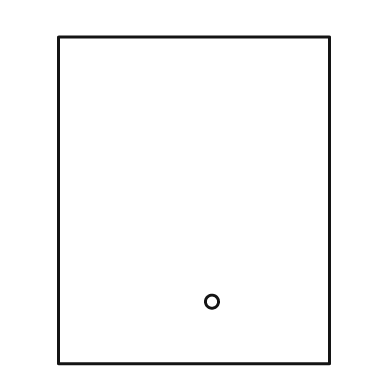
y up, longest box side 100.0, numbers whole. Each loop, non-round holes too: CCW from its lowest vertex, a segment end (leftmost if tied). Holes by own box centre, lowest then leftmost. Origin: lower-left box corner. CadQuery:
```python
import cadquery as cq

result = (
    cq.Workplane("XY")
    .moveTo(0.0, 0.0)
    .lineTo(83.0, 0.0)
    .lineTo(83.0, 100.0)
    .lineTo(0.0, 100.0)
    .close()
    .moveTo(47.0, 19.0)
    .circle(2.0)
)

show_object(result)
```